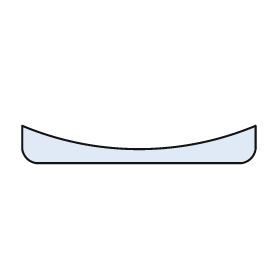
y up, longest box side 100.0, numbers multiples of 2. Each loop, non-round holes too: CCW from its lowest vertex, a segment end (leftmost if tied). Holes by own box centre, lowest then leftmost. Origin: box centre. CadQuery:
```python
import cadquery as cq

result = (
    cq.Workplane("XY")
    .moveTo(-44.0, -8.0)
    .lineTo(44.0, -8.0)
    .threePointArc((48.0, -6.0), (50.0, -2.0))
    .lineTo(50.0, 8.0)
    .threePointArc((0.0, -2.0), (-50.0, 8.0))
    .lineTo(-50.0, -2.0)
    .threePointArc((-48.0, -6.0), (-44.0, -8.0))
    .close()
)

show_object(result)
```